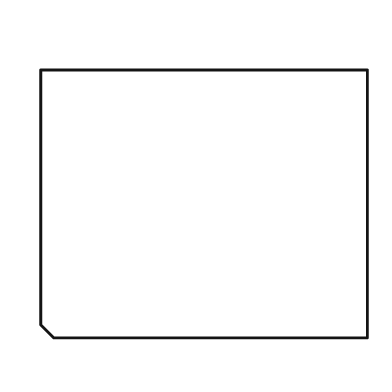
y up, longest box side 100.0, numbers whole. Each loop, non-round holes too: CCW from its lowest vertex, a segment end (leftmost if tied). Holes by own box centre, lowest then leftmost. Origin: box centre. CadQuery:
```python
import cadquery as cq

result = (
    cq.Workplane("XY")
    .moveTo(-46.0, -41.0)
    .lineTo(50.0, -41.0)
    .lineTo(50.0, 41.0)
    .lineTo(-50.0, 41.0)
    .lineTo(-50.0, -37.0)
    .close()
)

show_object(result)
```